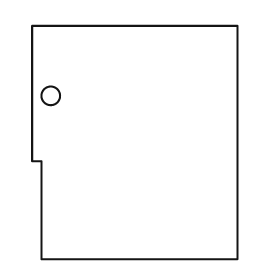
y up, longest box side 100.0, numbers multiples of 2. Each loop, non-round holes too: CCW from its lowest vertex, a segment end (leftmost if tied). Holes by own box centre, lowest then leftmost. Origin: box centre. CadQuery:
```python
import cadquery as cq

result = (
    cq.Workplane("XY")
    .moveTo(-40.0, -50.0)
    .lineTo(44.0, -50.0)
    .lineTo(44.0, 50.0)
    .lineTo(-44.0, 50.0)
    .lineTo(-44.0, -8.0)
    .lineTo(-40.0, -8.0)
    .close()
    .moveTo(-36.0, 20.0)
    .circle(4.0)
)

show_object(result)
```